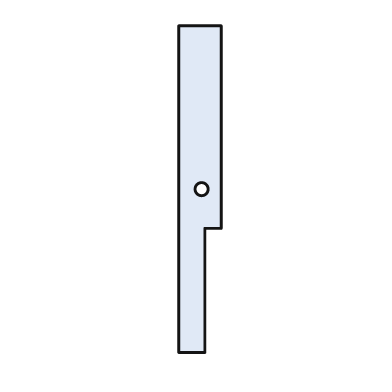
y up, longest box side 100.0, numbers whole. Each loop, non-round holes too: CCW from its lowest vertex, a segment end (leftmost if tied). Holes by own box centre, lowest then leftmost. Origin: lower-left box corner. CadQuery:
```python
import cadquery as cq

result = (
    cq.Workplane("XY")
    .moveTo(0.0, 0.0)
    .lineTo(8.0, 0.0)
    .lineTo(8.0, 38.0)
    .lineTo(13.0, 38.0)
    .lineTo(13.0, 100.0)
    .lineTo(0.0, 100.0)
    .close()
    .moveTo(7.0, 50.0)
    .circle(2.0)
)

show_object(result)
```